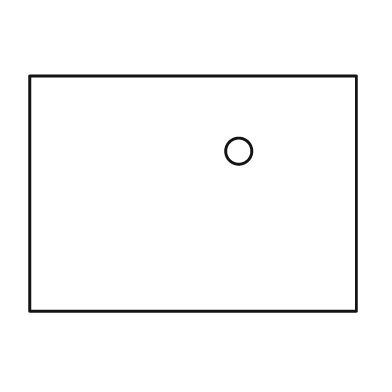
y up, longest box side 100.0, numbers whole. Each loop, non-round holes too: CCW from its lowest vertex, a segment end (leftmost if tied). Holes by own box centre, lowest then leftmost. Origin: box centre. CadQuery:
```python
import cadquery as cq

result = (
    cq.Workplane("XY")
    .moveTo(-50.0, -36.0)
    .lineTo(50.0, -36.0)
    .lineTo(50.0, 36.0)
    .lineTo(-50.0, 36.0)
    .close()
    .moveTo(14.0, 13.0)
    .circle(4.0)
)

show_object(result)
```